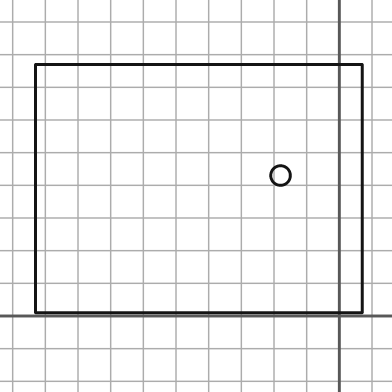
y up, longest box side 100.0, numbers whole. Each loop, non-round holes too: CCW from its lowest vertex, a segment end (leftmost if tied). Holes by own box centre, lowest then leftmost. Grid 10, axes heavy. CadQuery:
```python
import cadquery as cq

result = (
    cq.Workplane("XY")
    .moveTo(-93.0, 1.0)
    .lineTo(7.0, 1.0)
    .lineTo(7.0, 77.0)
    .lineTo(-93.0, 77.0)
    .close()
    .moveTo(-18.0, 43.0)
    .circle(3.0)
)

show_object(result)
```